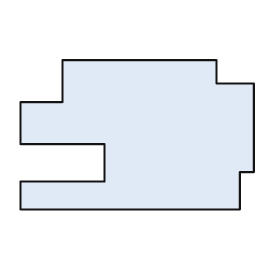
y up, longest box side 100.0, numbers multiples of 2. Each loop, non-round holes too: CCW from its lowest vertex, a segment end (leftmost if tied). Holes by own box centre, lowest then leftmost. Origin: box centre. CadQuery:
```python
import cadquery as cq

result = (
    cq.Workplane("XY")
    .moveTo(-50.0, -32.0)
    .lineTo(44.0, -32.0)
    .lineTo(44.0, -16.0)
    .lineTo(50.0, -16.0)
    .lineTo(50.0, 22.0)
    .lineTo(34.0, 22.0)
    .lineTo(34.0, 32.0)
    .lineTo(-32.0, 32.0)
    .lineTo(-32.0, 14.0)
    .lineTo(-50.0, 14.0)
    .lineTo(-50.0, -4.0)
    .lineTo(-14.0, -4.0)
    .lineTo(-14.0, -20.0)
    .lineTo(-50.0, -20.0)
    .close()
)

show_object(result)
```